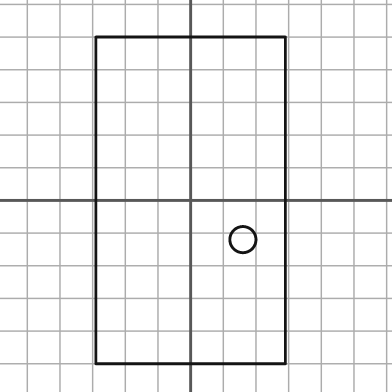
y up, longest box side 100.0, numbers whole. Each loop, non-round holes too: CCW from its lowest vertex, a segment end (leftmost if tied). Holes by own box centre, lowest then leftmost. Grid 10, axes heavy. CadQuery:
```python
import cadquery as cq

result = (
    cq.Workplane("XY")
    .moveTo(-29.0, -50.0)
    .lineTo(29.0, -50.0)
    .lineTo(29.0, 50.0)
    .lineTo(-29.0, 50.0)
    .close()
    .moveTo(16.0, -12.0)
    .circle(4.0)
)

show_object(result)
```